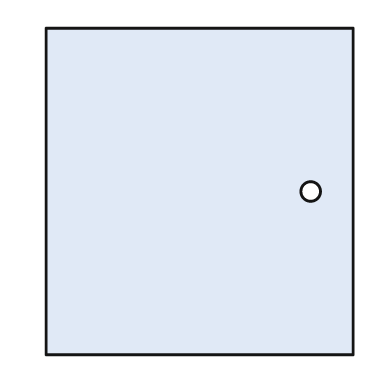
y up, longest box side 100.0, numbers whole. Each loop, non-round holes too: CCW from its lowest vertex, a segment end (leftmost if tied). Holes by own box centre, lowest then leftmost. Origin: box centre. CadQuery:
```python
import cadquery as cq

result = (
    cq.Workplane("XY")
    .moveTo(-47.0, -50.0)
    .lineTo(47.0, -50.0)
    .lineTo(47.0, 50.0)
    .lineTo(-47.0, 50.0)
    .close()
    .moveTo(34.0, 0.0)
    .circle(3.0)
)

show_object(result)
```